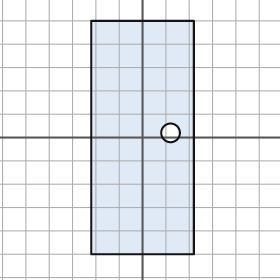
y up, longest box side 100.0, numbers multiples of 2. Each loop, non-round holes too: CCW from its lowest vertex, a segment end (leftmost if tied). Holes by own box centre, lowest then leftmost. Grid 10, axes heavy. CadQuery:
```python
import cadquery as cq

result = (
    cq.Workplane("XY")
    .moveTo(-22.0, -50.0)
    .lineTo(22.0, -50.0)
    .lineTo(22.0, 50.0)
    .lineTo(-22.0, 50.0)
    .close()
    .moveTo(12.0, 2.0)
    .circle(4.0)
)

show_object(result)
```